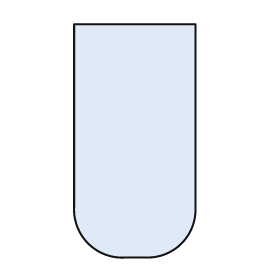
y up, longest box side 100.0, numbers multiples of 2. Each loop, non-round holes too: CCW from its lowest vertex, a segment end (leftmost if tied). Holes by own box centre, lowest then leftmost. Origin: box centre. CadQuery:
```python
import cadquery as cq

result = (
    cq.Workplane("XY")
    .moveTo(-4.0, -50.0)
    .lineTo(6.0, -50.0)
    .threePointArc((20.0, -44.0), (26.0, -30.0))
    .lineTo(26.0, 50.0)
    .lineTo(-26.0, 50.0)
    .lineTo(-26.0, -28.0)
    .threePointArc((-20.0, -44.0), (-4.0, -50.0))
    .close()
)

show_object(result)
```